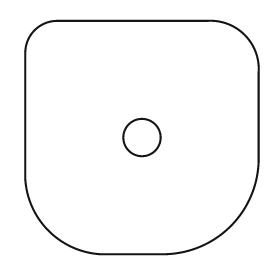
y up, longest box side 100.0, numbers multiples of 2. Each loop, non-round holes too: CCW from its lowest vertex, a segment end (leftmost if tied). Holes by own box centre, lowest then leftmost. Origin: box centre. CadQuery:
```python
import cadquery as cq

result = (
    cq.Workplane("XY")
    .moveTo(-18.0, -50.0)
    .lineTo(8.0, -50.0)
    .threePointArc((38.0, -38.0), (50.0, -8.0))
    .lineTo(50.0, 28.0)
    .threePointArc((44.0, 44.0), (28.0, 50.0))
    .lineTo(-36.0, 50.0)
    .threePointArc((-46.0, 46.0), (-50.0, 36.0))
    .lineTo(-50.0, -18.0)
    .threePointArc((-40.0, -40.0), (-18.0, -50.0))
    .close()
    .moveTo(0.0, 0.0)
    .circle(8.0)
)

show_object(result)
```